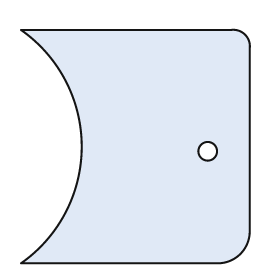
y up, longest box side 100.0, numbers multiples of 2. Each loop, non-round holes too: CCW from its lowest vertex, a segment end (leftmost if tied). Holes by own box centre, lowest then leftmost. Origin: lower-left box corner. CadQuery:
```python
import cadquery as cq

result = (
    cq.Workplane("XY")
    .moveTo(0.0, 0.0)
    .lineTo(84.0, 0.0)
    .threePointArc((94.0, 4.0), (98.0, 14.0))
    .lineTo(98.0, 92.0)
    .threePointArc((96.0, 98.0), (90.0, 100.0))
    .lineTo(0.0, 100.0)
    .threePointArc((26.0, 50.0), (0.0, 0.0))
    .close()
    .moveTo(80.0, 48.0)
    .circle(4.0)
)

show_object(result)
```